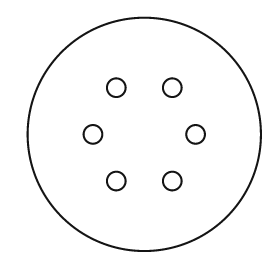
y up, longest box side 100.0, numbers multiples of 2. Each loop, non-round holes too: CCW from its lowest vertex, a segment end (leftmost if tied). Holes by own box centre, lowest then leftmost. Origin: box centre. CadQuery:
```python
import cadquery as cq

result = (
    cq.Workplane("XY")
    .moveTo(0.0, 0.0)
    .circle(50.0)
    .moveTo(-12.0, -20.0)
    .circle(4.0)
    .moveTo(12.0, -20.0)
    .circle(4.0)
    .moveTo(-22.0, 0.0)
    .circle(4.0)
    .moveTo(22.0, 0.0)
    .circle(4.0)
    .moveTo(-12.0, 20.0)
    .circle(4.0)
    .moveTo(12.0, 20.0)
    .circle(4.0)
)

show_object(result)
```